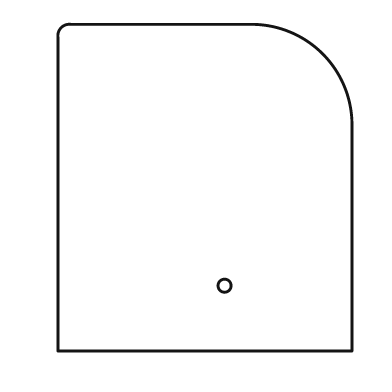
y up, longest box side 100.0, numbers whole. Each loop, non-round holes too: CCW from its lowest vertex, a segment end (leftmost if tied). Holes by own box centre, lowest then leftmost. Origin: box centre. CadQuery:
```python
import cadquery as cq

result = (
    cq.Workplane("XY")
    .moveTo(-45.0, -50.0)
    .lineTo(45.0, -50.0)
    .lineTo(45.0, 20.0)
    .threePointArc((36.0, 41.0), (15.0, 50.0))
    .lineTo(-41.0, 50.0)
    .threePointArc((-44.0, 49.0), (-45.0, 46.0))
    .close()
    .moveTo(6.0, -30.0)
    .circle(2.0)
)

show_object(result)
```